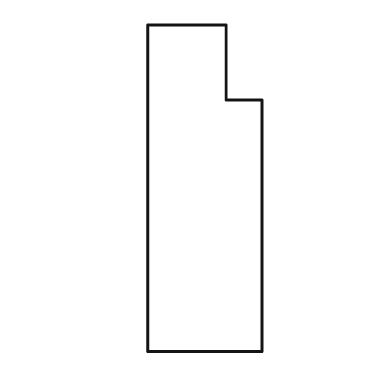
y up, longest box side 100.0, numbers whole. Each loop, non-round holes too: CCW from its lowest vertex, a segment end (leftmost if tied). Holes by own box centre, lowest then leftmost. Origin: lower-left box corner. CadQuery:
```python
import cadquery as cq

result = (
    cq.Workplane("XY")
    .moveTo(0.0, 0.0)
    .lineTo(35.0, 0.0)
    .lineTo(35.0, 77.0)
    .lineTo(24.0, 77.0)
    .lineTo(24.0, 100.0)
    .lineTo(0.0, 100.0)
    .close()
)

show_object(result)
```